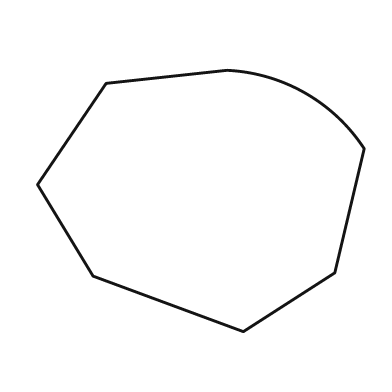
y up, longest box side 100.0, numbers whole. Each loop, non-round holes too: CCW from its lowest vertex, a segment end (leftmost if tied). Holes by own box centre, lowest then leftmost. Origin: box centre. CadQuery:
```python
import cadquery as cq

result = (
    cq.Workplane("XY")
    .moveTo(13.0, -40.0)
    .lineTo(41.0, -22.0)
    .lineTo(50.0, 16.0)
    .threePointArc((32.0, 33.0), (8.0, 40.0))
    .lineTo(-29.0, 36.0)
    .lineTo(-50.0, 5.0)
    .lineTo(-33.0, -23.0)
    .close()
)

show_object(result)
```